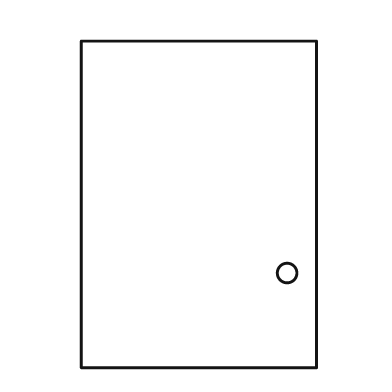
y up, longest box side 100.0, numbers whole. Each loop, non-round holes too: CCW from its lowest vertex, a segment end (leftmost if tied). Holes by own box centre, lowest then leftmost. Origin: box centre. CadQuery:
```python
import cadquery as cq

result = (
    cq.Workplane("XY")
    .moveTo(-36.0, -50.0)
    .lineTo(36.0, -50.0)
    .lineTo(36.0, 50.0)
    .lineTo(-36.0, 50.0)
    .close()
    .moveTo(27.0, -21.0)
    .circle(3.0)
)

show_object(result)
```